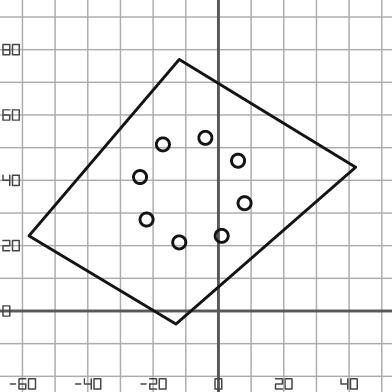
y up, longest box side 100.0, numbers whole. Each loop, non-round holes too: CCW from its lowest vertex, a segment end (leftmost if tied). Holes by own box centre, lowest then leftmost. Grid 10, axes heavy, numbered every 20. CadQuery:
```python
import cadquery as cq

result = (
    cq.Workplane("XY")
    .moveTo(-13.0, -4.0)
    .lineTo(42.0, 44.0)
    .lineTo(-12.0, 77.0)
    .lineTo(-58.0, 23.0)
    .close()
    .moveTo(-12.0, 21.0)
    .circle(2.0)
    .moveTo(1.0, 23.0)
    .circle(2.0)
    .moveTo(-22.0, 28.0)
    .circle(2.0)
    .moveTo(8.0, 33.0)
    .circle(2.0)
    .moveTo(-24.0, 41.0)
    .circle(2.0)
    .moveTo(6.0, 46.0)
    .circle(2.0)
    .moveTo(-17.0, 51.0)
    .circle(2.0)
    .moveTo(-4.0, 53.0)
    .circle(2.0)
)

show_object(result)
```